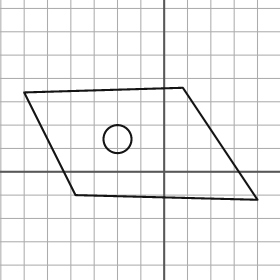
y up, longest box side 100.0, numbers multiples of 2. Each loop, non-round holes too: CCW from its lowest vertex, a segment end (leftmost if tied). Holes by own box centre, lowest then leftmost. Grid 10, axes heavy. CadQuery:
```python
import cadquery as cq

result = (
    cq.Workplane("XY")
    .moveTo(40.0, -12.0)
    .lineTo(8.0, 36.0)
    .lineTo(-60.0, 34.0)
    .lineTo(-38.0, -10.0)
    .close()
    .moveTo(-20.0, 14.0)
    .circle(6.0)
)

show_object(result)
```